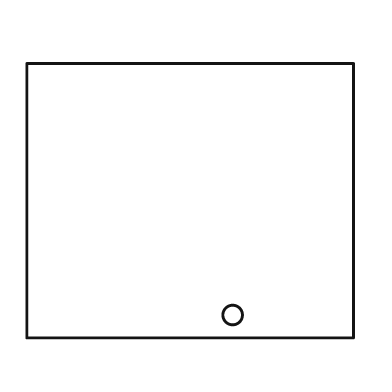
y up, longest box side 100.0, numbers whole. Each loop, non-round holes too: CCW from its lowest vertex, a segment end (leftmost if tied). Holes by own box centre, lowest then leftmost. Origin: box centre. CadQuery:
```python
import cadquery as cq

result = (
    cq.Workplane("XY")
    .moveTo(-50.0, -42.0)
    .lineTo(50.0, -42.0)
    .lineTo(50.0, 42.0)
    .lineTo(-50.0, 42.0)
    .close()
    .moveTo(13.0, -35.0)
    .circle(3.0)
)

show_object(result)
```